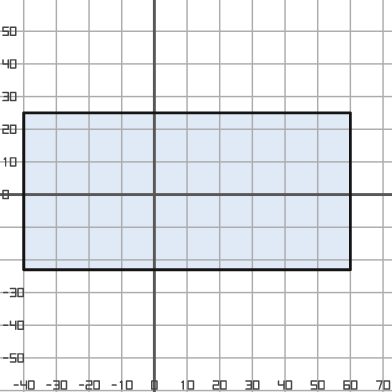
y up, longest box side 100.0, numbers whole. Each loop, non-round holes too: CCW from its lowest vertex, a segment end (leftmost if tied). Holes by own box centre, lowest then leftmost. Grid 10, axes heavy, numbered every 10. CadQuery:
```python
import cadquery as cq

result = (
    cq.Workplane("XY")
    .moveTo(-40.0, -23.0)
    .lineTo(60.0, -23.0)
    .lineTo(60.0, 25.0)
    .lineTo(-40.0, 25.0)
    .close()
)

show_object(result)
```